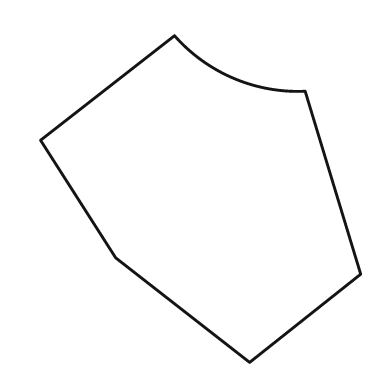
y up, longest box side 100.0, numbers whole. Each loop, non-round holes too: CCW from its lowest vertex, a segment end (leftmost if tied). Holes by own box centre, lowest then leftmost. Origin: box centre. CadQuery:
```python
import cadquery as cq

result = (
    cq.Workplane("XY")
    .moveTo(15.0, -50.0)
    .lineTo(49.0, -23.0)
    .lineTo(32.0, 33.0)
    .threePointArc((10.0, 37.0), (-8.0, 50.0))
    .lineTo(-49.0, 18.0)
    .lineTo(-26.0, -18.0)
    .close()
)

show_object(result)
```